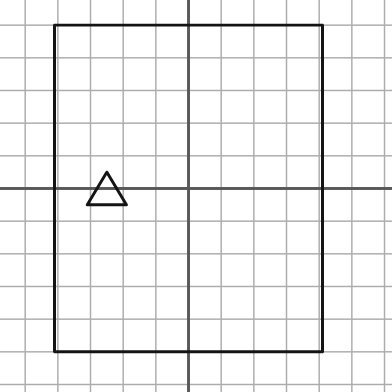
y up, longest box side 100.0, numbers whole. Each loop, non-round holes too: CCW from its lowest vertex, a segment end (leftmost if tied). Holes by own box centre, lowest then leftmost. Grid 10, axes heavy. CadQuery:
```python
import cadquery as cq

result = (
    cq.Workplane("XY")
    .moveTo(-41.0, -50.0)
    .lineTo(41.0, -50.0)
    .lineTo(41.0, 50.0)
    .lineTo(-41.0, 50.0)
    .close()
    .moveTo(-31.0, -5.0)
    .lineTo(-19.0, -5.0)
    .lineTo(-25.0, 5.0)
    .close()
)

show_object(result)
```